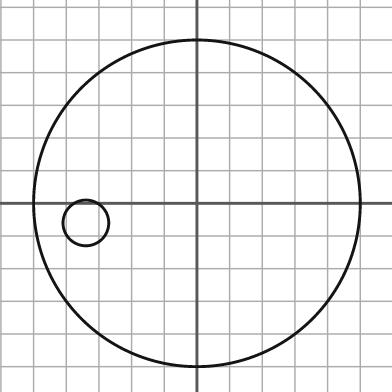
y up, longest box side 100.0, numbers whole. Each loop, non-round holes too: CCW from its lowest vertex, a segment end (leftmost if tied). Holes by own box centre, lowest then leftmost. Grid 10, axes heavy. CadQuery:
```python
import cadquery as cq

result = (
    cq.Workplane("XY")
    .moveTo(0.0, 0.0)
    .circle(50.0)
    .moveTo(-34.0, -6.0)
    .circle(7.0)
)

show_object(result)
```